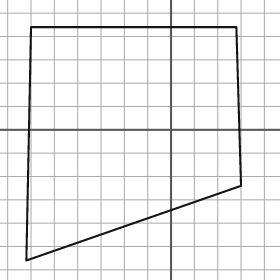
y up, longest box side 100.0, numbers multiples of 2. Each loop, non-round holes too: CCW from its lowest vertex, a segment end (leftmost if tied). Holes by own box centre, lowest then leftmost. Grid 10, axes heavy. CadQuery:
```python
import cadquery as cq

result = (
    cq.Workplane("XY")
    .moveTo(-62.0, -56.0)
    .lineTo(30.0, -24.0)
    .lineTo(28.0, 44.0)
    .lineTo(-60.0, 44.0)
    .close()
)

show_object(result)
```